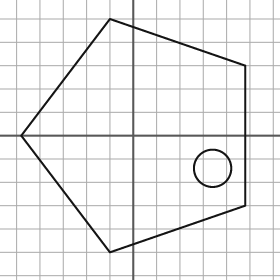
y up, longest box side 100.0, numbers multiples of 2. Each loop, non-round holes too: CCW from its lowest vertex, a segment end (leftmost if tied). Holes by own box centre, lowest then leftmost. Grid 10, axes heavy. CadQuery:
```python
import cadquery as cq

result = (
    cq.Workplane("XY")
    .moveTo(-10.0, -50.0)
    .lineTo(48.0, -30.0)
    .lineTo(48.0, 30.0)
    .lineTo(-10.0, 50.0)
    .lineTo(-48.0, 0.0)
    .close()
    .moveTo(34.0, -14.0)
    .circle(8.0)
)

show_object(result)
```